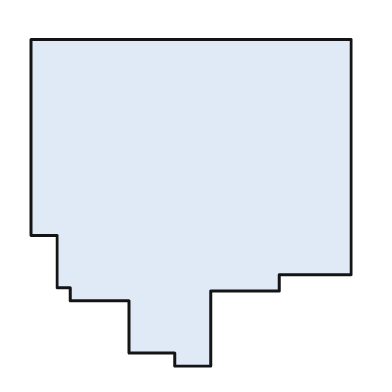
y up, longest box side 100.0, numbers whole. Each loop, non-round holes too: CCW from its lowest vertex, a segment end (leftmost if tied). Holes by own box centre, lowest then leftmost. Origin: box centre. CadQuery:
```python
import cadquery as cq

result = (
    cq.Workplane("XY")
    .moveTo(-5.0, -50.0)
    .lineTo(6.0, -50.0)
    .lineTo(6.0, -27.0)
    .lineTo(27.0, -27.0)
    .lineTo(27.0, -22.0)
    .lineTo(49.0, -22.0)
    .lineTo(49.0, 50.0)
    .lineTo(-49.0, 50.0)
    .lineTo(-49.0, -10.0)
    .lineTo(-41.0, -10.0)
    .lineTo(-41.0, -26.0)
    .lineTo(-37.0, -26.0)
    .lineTo(-37.0, -30.0)
    .lineTo(-19.0, -30.0)
    .lineTo(-19.0, -46.0)
    .lineTo(-5.0, -46.0)
    .close()
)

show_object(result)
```